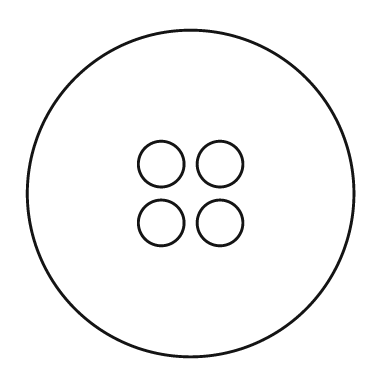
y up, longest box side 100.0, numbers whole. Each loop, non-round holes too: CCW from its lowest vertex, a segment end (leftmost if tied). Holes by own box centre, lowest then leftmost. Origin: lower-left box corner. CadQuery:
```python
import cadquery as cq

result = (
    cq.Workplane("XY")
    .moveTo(50.0, 50.0)
    .circle(50.0)
    .moveTo(41.0, 41.0)
    .circle(7.0)
    .moveTo(59.0, 41.0)
    .circle(7.0)
    .moveTo(41.0, 59.0)
    .circle(7.0)
    .moveTo(59.0, 59.0)
    .circle(7.0)
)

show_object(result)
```